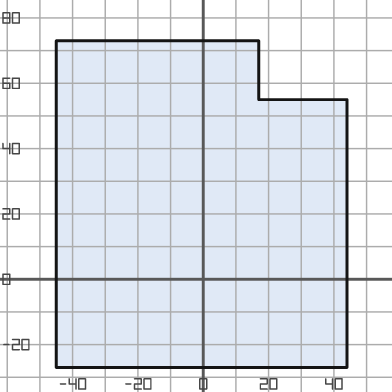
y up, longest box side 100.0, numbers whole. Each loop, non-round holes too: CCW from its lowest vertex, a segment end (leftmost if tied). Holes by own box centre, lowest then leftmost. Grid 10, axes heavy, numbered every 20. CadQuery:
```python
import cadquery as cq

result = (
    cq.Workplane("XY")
    .moveTo(-45.0, -27.0)
    .lineTo(44.0, -27.0)
    .lineTo(44.0, 55.0)
    .lineTo(17.0, 55.0)
    .lineTo(17.0, 73.0)
    .lineTo(-45.0, 73.0)
    .close()
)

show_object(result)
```